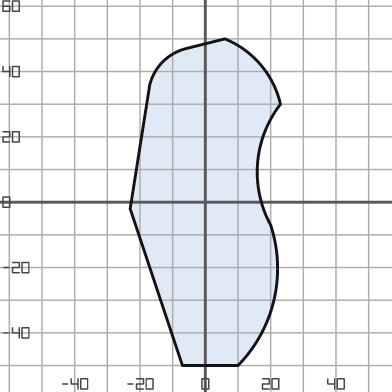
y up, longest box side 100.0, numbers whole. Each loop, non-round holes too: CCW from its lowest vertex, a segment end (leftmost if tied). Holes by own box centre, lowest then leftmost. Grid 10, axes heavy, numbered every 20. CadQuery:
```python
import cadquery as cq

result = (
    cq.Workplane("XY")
    .moveTo(-7.0, -50.0)
    .lineTo(10.0, -50.0)
    .threePointArc((21.0, -30.0), (20.0, -7.0))
    .threePointArc((16.0, 12.0), (23.0, 30.0))
    .threePointArc((17.0, 42.0), (6.0, 50.0))
    .lineTo(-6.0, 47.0)
    .threePointArc((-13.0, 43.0), (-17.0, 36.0))
    .lineTo(-23.0, -2.0)
    .close()
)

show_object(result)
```